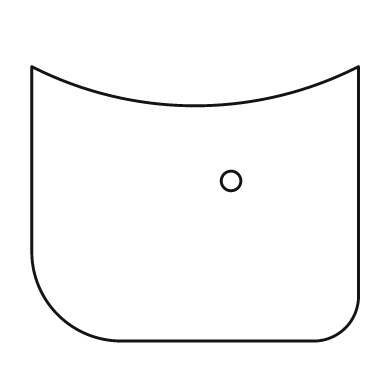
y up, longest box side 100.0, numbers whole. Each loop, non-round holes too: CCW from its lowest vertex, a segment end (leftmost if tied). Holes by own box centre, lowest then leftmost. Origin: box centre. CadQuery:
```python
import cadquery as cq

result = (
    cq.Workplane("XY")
    .moveTo(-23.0, -42.0)
    .lineTo(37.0, -42.0)
    .threePointArc((46.0, -38.0), (50.0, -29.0))
    .lineTo(50.0, 42.0)
    .threePointArc((0.0, 30.0), (-50.0, 42.0))
    .lineTo(-50.0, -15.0)
    .threePointArc((-42.0, -34.0), (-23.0, -42.0))
    .close()
    .moveTo(11.0, 7.0)
    .circle(3.0)
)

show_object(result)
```